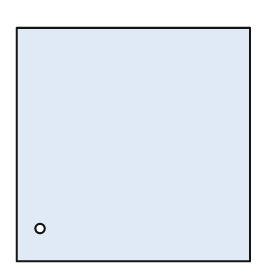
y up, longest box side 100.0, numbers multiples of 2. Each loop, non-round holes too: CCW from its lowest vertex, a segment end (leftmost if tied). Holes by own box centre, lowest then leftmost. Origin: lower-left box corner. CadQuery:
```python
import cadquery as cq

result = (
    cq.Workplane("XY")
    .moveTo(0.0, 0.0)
    .lineTo(100.0, 0.0)
    .lineTo(100.0, 100.0)
    .lineTo(0.0, 100.0)
    .close()
    .moveTo(10.0, 14.0)
    .circle(2.0)
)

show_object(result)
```